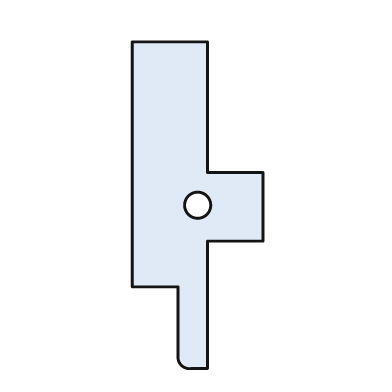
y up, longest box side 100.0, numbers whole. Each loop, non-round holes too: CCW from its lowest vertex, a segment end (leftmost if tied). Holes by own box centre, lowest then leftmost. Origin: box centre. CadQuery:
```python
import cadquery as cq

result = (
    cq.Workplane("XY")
    .moveTo(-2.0, -50.0)
    .lineTo(3.0, -50.0)
    .lineTo(3.0, -11.0)
    .lineTo(20.0, -11.0)
    .lineTo(20.0, 10.0)
    .lineTo(3.0, 10.0)
    .lineTo(3.0, 50.0)
    .lineTo(-20.0, 50.0)
    .lineTo(-20.0, -25.0)
    .lineTo(-6.0, -25.0)
    .lineTo(-6.0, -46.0)
    .threePointArc((-5.0, -49.0), (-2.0, -50.0))
    .close()
    .moveTo(0.0, 0.0)
    .circle(4.0)
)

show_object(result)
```